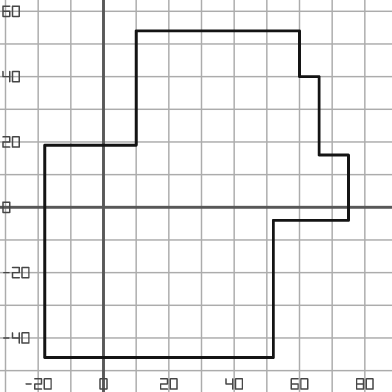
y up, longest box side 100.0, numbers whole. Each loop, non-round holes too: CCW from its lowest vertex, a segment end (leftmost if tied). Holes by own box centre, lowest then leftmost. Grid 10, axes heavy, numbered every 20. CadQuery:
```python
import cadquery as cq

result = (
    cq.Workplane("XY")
    .moveTo(-18.0, -46.0)
    .lineTo(52.0, -46.0)
    .lineTo(52.0, -4.0)
    .lineTo(75.0, -4.0)
    .lineTo(75.0, 16.0)
    .lineTo(66.0, 16.0)
    .lineTo(66.0, 40.0)
    .lineTo(60.0, 40.0)
    .lineTo(60.0, 54.0)
    .lineTo(10.0, 54.0)
    .lineTo(10.0, 19.0)
    .lineTo(-18.0, 19.0)
    .close()
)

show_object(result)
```